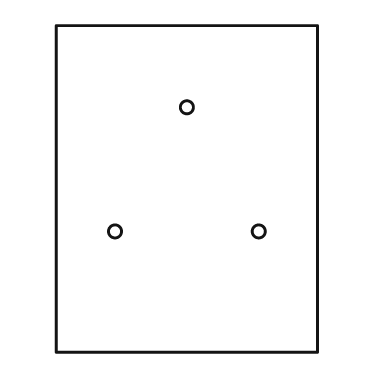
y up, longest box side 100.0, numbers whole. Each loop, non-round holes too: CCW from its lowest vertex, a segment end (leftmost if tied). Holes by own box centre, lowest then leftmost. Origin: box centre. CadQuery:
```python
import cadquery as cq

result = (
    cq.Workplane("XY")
    .moveTo(-40.0, -50.0)
    .lineTo(40.0, -50.0)
    .lineTo(40.0, 50.0)
    .lineTo(-40.0, 50.0)
    .close()
    .moveTo(-22.0, -13.0)
    .circle(2.0)
    .moveTo(22.0, -13.0)
    .circle(2.0)
    .moveTo(0.0, 25.0)
    .circle(2.0)
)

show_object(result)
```